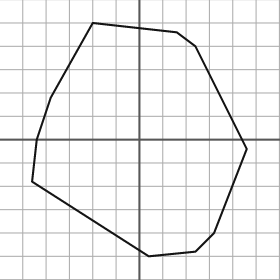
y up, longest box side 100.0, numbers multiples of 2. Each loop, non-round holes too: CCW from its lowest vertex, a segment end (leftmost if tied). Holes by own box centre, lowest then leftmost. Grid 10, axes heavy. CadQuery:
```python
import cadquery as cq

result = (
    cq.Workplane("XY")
    .moveTo(4.0, -50.0)
    .lineTo(24.0, -48.0)
    .lineTo(32.0, -40.0)
    .lineTo(46.0, -4.0)
    .lineTo(24.0, 40.0)
    .lineTo(16.0, 46.0)
    .lineTo(-20.0, 50.0)
    .lineTo(-38.0, 18.0)
    .lineTo(-44.0, 0.0)
    .lineTo(-46.0, -18.0)
    .close()
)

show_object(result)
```